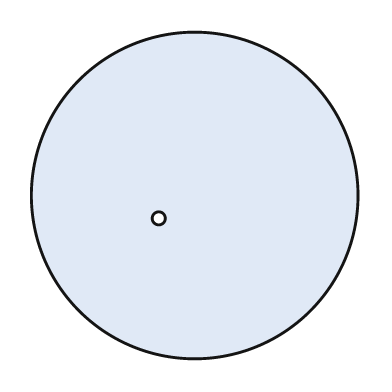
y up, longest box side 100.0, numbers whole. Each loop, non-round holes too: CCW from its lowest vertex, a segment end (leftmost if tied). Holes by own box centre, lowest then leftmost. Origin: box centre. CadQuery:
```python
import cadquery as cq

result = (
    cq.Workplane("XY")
    .moveTo(0.0, 0.0)
    .circle(50.0)
    .moveTo(-11.0, -7.0)
    .circle(2.0)
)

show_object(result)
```